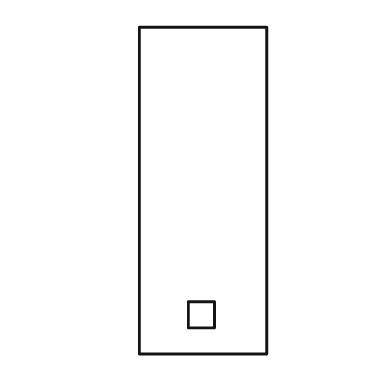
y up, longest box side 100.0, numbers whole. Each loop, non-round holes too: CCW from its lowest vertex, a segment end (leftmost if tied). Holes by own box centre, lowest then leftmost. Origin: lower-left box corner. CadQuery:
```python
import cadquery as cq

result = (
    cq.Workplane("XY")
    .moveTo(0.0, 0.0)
    .lineTo(39.0, 0.0)
    .lineTo(39.0, 100.0)
    .lineTo(0.0, 100.0)
    .close()
    .moveTo(15.0, 8.0)
    .lineTo(23.0, 8.0)
    .lineTo(23.0, 16.0)
    .lineTo(15.0, 16.0)
    .close()
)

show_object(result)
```